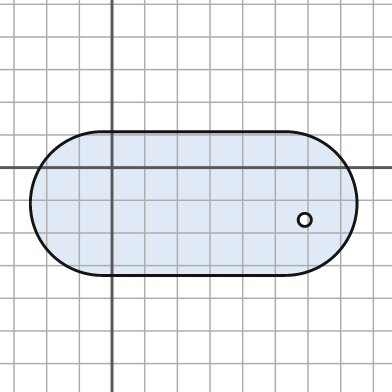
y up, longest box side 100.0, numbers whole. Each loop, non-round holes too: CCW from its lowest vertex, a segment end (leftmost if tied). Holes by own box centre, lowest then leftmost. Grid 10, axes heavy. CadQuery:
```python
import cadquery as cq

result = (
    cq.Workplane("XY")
    .moveTo(-3.0, -33.0)
    .lineTo(53.0, -33.0)
    .threePointArc((75.0, -11.0), (53.0, 11.0))
    .lineTo(-3.0, 11.0)
    .threePointArc((-25.0, -11.0), (-3.0, -33.0))
    .close()
    .moveTo(59.0, -16.0)
    .circle(2.0)
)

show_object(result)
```